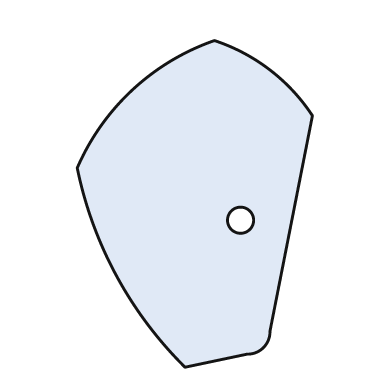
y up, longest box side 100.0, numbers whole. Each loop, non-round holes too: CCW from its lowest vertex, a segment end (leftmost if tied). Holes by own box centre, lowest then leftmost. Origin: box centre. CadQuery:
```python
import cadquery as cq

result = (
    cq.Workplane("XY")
    .moveTo(-3.0, -50.0)
    .lineTo(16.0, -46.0)
    .threePointArc((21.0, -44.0), (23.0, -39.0))
    .lineTo(36.0, 27.0)
    .threePointArc((23.0, 41.0), (6.0, 50.0))
    .threePointArc((-19.0, 35.0), (-36.0, 11.0))
    .threePointArc((-24.0, -22.0), (-3.0, -50.0))
    .close()
    .moveTo(14.0, -5.0)
    .circle(4.0)
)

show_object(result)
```